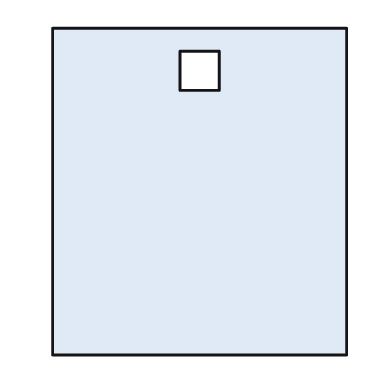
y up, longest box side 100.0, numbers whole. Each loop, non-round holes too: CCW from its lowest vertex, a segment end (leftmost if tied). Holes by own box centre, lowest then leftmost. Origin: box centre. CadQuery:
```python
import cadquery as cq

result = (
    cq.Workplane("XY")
    .moveTo(-45.0, -50.0)
    .lineTo(45.0, -50.0)
    .lineTo(45.0, 50.0)
    .lineTo(-45.0, 50.0)
    .close()
    .moveTo(-6.0, 31.0)
    .lineTo(6.0, 31.0)
    .lineTo(6.0, 43.0)
    .lineTo(-6.0, 43.0)
    .close()
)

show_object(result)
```